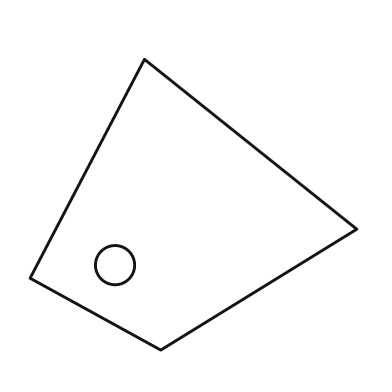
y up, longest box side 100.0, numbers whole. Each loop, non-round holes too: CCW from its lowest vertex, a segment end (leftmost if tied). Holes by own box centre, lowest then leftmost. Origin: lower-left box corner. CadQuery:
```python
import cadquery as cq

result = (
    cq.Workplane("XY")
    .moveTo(40.0, 0.0)
    .lineTo(100.0, 37.0)
    .lineTo(35.0, 89.0)
    .lineTo(0.0, 22.0)
    .close()
    .moveTo(26.0, 26.0)
    .circle(6.0)
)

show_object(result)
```